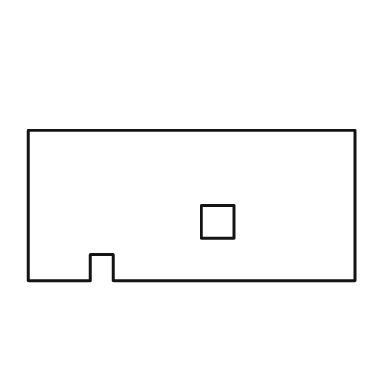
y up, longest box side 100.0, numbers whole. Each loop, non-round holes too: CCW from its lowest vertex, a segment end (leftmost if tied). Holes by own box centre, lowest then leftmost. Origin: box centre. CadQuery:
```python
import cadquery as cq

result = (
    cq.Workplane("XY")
    .moveTo(-50.0, -23.0)
    .lineTo(-31.0, -23.0)
    .lineTo(-31.0, -15.0)
    .lineTo(-24.0, -15.0)
    .lineTo(-24.0, -23.0)
    .lineTo(50.0, -23.0)
    .lineTo(50.0, 23.0)
    .lineTo(-50.0, 23.0)
    .close()
    .moveTo(3.0, -10.0)
    .lineTo(13.0, -10.0)
    .lineTo(13.0, 0.0)
    .lineTo(3.0, 0.0)
    .close()
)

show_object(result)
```